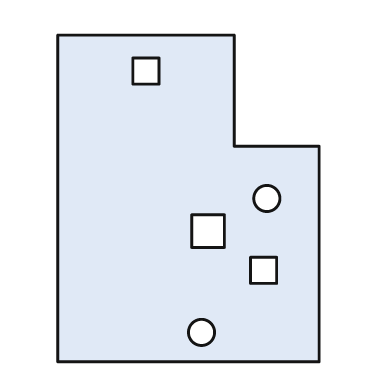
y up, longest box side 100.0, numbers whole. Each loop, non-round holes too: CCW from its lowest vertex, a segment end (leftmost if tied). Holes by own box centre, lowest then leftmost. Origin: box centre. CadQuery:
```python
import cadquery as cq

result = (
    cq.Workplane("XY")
    .moveTo(-40.0, -50.0)
    .lineTo(40.0, -50.0)
    .lineTo(40.0, 16.0)
    .lineTo(14.0, 16.0)
    .lineTo(14.0, 50.0)
    .lineTo(-40.0, 50.0)
    .close()
    .moveTo(4.0, -41.0)
    .circle(4.0)
    .moveTo(19.0, -26.0)
    .lineTo(27.0, -26.0)
    .lineTo(27.0, -18.0)
    .lineTo(19.0, -18.0)
    .close()
    .moveTo(1.0, -15.0)
    .lineTo(11.0, -15.0)
    .lineTo(11.0, -5.0)
    .lineTo(1.0, -5.0)
    .close()
    .moveTo(24.0, 0.0)
    .circle(4.0)
    .moveTo(-17.0, 35.0)
    .lineTo(-9.0, 35.0)
    .lineTo(-9.0, 43.0)
    .lineTo(-17.0, 43.0)
    .close()
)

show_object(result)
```